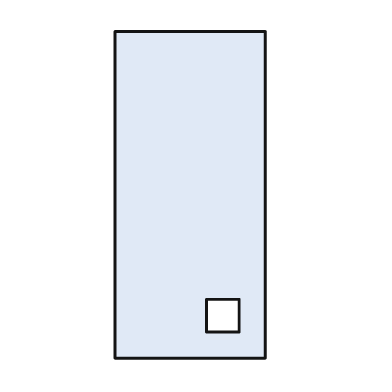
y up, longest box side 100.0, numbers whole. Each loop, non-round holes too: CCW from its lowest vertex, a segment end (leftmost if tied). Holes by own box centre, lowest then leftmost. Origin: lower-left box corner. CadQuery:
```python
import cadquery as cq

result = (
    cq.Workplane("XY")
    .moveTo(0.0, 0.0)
    .lineTo(46.0, 0.0)
    .lineTo(46.0, 100.0)
    .lineTo(0.0, 100.0)
    .close()
    .moveTo(28.0, 8.0)
    .lineTo(38.0, 8.0)
    .lineTo(38.0, 18.0)
    .lineTo(28.0, 18.0)
    .close()
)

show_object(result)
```